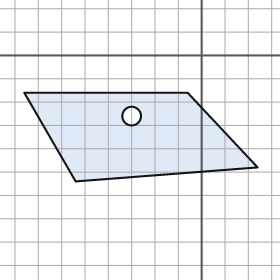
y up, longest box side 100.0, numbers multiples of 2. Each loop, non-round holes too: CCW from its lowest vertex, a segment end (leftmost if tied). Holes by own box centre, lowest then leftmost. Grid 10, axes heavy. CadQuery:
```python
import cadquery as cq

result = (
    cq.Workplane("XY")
    .moveTo(-54.0, -54.0)
    .lineTo(24.0, -48.0)
    .lineTo(-6.0, -16.0)
    .lineTo(-76.0, -16.0)
    .close()
    .moveTo(-30.0, -26.0)
    .circle(4.0)
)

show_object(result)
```